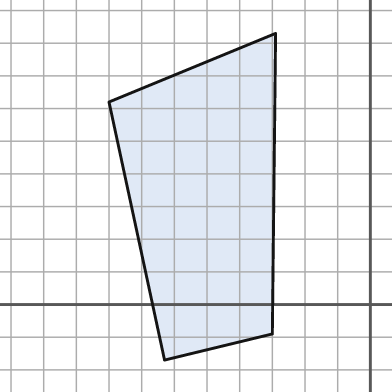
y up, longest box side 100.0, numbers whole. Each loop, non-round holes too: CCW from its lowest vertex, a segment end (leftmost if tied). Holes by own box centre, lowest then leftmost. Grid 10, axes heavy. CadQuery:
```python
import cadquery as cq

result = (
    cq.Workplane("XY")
    .moveTo(-63.0, -17.0)
    .lineTo(-30.0, -9.0)
    .lineTo(-29.0, 83.0)
    .lineTo(-80.0, 62.0)
    .close()
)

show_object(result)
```